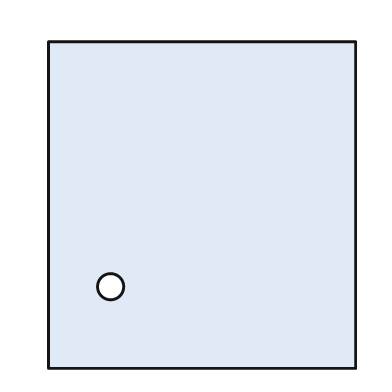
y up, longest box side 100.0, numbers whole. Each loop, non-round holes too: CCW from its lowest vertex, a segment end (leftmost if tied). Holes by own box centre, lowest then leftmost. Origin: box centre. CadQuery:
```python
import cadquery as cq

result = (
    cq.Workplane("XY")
    .moveTo(-47.0, -50.0)
    .lineTo(47.0, -50.0)
    .lineTo(47.0, 50.0)
    .lineTo(-47.0, 50.0)
    .close()
    .moveTo(-28.0, -25.0)
    .circle(4.0)
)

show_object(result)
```